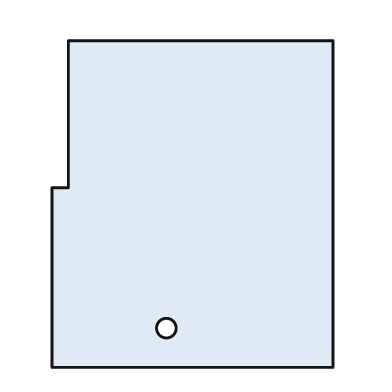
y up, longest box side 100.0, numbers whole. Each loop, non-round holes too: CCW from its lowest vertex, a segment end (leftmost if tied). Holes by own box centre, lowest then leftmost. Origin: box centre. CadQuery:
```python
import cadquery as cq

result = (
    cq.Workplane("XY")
    .moveTo(-43.0, -50.0)
    .lineTo(43.0, -50.0)
    .lineTo(43.0, 50.0)
    .lineTo(-38.0, 50.0)
    .lineTo(-38.0, 5.0)
    .lineTo(-43.0, 5.0)
    .close()
    .moveTo(-8.0, -38.0)
    .circle(3.0)
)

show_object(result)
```